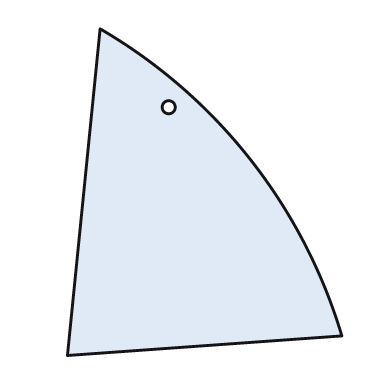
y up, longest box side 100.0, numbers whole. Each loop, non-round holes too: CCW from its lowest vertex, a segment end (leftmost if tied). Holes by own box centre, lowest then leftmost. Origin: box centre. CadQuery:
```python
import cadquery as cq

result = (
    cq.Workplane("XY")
    .moveTo(-42.0, -50.0)
    .lineTo(42.0, -44.0)
    .threePointArc((14.0, 10.0), (-32.0, 50.0))
    .close()
    .moveTo(-11.0, 26.0)
    .circle(2.0)
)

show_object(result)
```